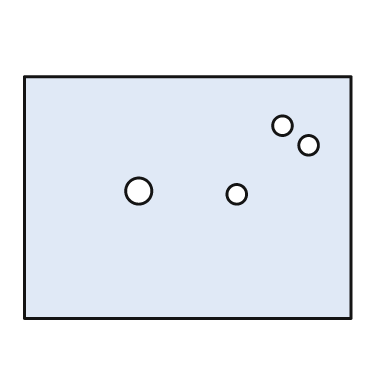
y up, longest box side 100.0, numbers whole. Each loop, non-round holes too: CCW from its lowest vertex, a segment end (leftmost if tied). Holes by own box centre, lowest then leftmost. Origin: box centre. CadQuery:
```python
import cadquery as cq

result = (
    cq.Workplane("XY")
    .moveTo(-50.0, -37.0)
    .lineTo(50.0, -37.0)
    .lineTo(50.0, 37.0)
    .lineTo(-50.0, 37.0)
    .close()
    .moveTo(15.0, 1.0)
    .circle(3.0)
    .moveTo(-15.0, 2.0)
    .circle(4.0)
    .moveTo(37.0, 16.0)
    .circle(3.0)
    .moveTo(29.0, 22.0)
    .circle(3.0)
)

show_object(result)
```